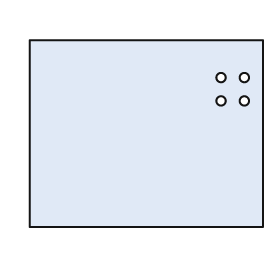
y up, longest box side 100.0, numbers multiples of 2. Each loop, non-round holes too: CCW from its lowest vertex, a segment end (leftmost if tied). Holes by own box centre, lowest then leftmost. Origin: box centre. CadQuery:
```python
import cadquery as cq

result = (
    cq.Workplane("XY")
    .moveTo(-50.0, -40.0)
    .lineTo(50.0, -40.0)
    .lineTo(50.0, 40.0)
    .lineTo(-50.0, 40.0)
    .close()
    .moveTo(32.0, 14.0)
    .circle(2.0)
    .moveTo(42.0, 14.0)
    .circle(2.0)
    .moveTo(32.0, 24.0)
    .circle(2.0)
    .moveTo(42.0, 24.0)
    .circle(2.0)
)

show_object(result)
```